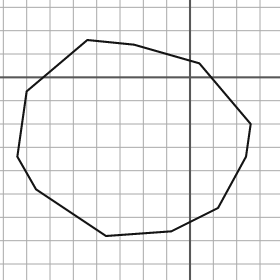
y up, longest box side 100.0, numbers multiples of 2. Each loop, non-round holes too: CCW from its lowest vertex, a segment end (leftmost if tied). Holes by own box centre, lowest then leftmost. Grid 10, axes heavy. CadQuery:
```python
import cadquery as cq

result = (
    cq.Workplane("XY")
    .moveTo(-36.0, -68.0)
    .lineTo(-8.0, -66.0)
    .lineTo(12.0, -56.0)
    .lineTo(24.0, -34.0)
    .lineTo(26.0, -20.0)
    .lineTo(4.0, 6.0)
    .lineTo(-24.0, 14.0)
    .lineTo(-44.0, 16.0)
    .lineTo(-70.0, -6.0)
    .lineTo(-74.0, -34.0)
    .lineTo(-66.0, -48.0)
    .close()
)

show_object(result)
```